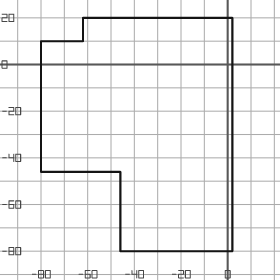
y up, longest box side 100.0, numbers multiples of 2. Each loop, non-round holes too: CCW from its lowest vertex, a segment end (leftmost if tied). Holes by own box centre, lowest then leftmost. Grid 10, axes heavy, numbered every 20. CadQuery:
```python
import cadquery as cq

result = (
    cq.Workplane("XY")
    .moveTo(-46.0, -80.0)
    .lineTo(2.0, -80.0)
    .lineTo(2.0, 20.0)
    .lineTo(-62.0, 20.0)
    .lineTo(-62.0, 10.0)
    .lineTo(-80.0, 10.0)
    .lineTo(-80.0, -46.0)
    .lineTo(-46.0, -46.0)
    .close()
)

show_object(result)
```